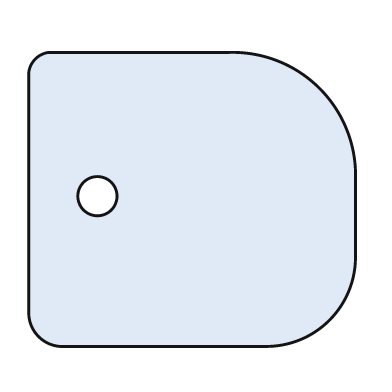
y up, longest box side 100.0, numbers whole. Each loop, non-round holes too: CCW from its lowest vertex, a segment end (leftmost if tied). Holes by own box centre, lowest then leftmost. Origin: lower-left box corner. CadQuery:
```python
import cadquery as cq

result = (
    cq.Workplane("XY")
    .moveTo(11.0, 0.0)
    .lineTo(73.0, 0.0)
    .threePointArc((92.0, 8.0), (100.0, 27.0))
    .lineTo(100.0, 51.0)
    .threePointArc((89.0, 79.0), (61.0, 90.0))
    .lineTo(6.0, 90.0)
    .threePointArc((2.0, 88.0), (0.0, 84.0))
    .lineTo(0.0, 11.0)
    .threePointArc((3.0, 3.0), (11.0, 0.0))
    .close()
    .moveTo(21.0, 46.0)
    .circle(6.0)
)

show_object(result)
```